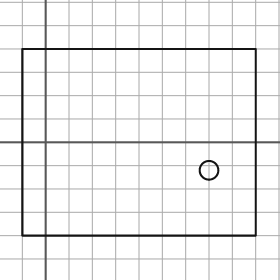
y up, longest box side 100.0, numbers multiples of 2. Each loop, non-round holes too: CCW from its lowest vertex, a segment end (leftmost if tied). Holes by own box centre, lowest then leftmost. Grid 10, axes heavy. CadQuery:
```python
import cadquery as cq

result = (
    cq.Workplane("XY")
    .moveTo(-10.0, -40.0)
    .lineTo(90.0, -40.0)
    .lineTo(90.0, 40.0)
    .lineTo(-10.0, 40.0)
    .close()
    .moveTo(70.0, -12.0)
    .circle(4.0)
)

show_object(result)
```